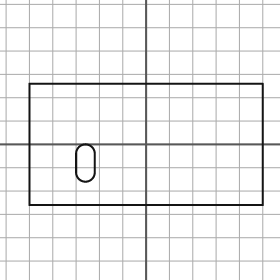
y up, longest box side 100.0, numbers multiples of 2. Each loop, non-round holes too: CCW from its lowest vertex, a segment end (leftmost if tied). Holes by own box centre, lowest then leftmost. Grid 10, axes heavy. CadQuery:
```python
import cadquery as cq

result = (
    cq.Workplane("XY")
    .moveTo(-50.0, -26.0)
    .lineTo(50.0, -26.0)
    .lineTo(50.0, 26.0)
    .lineTo(-50.0, 26.0)
    .close()
    .moveTo(-30.0, -12.0)
    .threePointArc((-26.0, -16.0), (-22.0, -12.0))
    .lineTo(-22.0, -4.0)
    .threePointArc((-26.0, 0.0), (-30.0, -4.0))
    .close()
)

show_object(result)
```